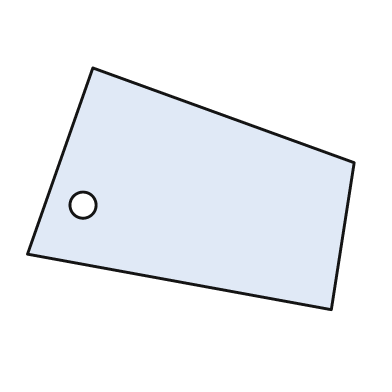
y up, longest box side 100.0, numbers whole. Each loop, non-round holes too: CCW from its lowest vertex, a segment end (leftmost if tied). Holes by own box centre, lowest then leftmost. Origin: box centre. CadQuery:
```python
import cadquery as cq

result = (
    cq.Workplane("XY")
    .moveTo(43.0, -37.0)
    .lineTo(50.0, 8.0)
    .lineTo(-30.0, 37.0)
    .lineTo(-50.0, -20.0)
    .close()
    .moveTo(-33.0, -5.0)
    .circle(4.0)
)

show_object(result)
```